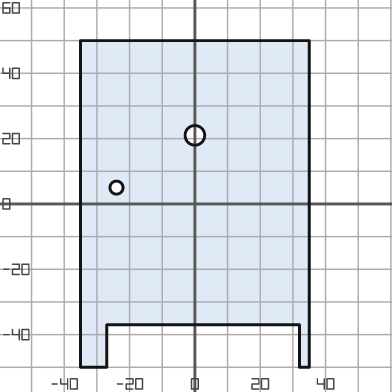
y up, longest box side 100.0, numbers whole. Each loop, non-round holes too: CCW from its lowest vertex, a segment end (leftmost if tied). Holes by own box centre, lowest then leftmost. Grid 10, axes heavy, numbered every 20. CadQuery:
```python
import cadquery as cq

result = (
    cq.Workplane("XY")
    .moveTo(-35.0, -50.0)
    .lineTo(-27.0, -50.0)
    .lineTo(-27.0, -37.0)
    .lineTo(32.0, -37.0)
    .lineTo(32.0, -50.0)
    .lineTo(35.0, -50.0)
    .lineTo(35.0, 50.0)
    .lineTo(-35.0, 50.0)
    .close()
    .moveTo(-24.0, 5.0)
    .circle(2.0)
    .moveTo(0.0, 21.0)
    .circle(3.0)
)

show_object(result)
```